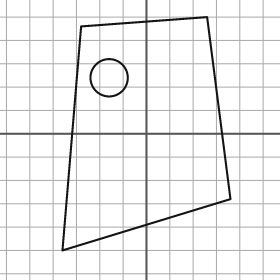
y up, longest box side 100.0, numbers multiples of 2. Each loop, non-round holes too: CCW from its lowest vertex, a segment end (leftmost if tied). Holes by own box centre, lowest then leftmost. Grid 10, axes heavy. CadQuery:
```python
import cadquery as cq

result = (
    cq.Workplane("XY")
    .moveTo(-36.0, -50.0)
    .lineTo(36.0, -28.0)
    .lineTo(26.0, 50.0)
    .lineTo(-28.0, 46.0)
    .close()
    .moveTo(-16.0, 24.0)
    .circle(8.0)
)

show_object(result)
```